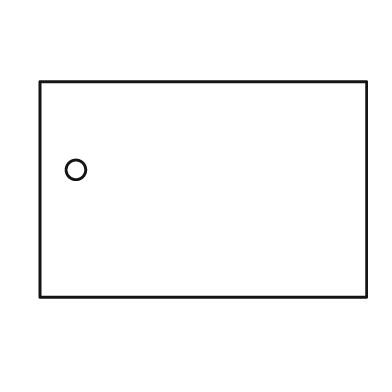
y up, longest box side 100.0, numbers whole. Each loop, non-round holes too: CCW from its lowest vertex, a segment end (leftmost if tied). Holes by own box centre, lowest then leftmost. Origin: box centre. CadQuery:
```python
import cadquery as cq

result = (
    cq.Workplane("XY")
    .moveTo(-50.0, -33.0)
    .lineTo(50.0, -33.0)
    .lineTo(50.0, 33.0)
    .lineTo(-50.0, 33.0)
    .close()
    .moveTo(-39.0, 6.0)
    .circle(3.0)
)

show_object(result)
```